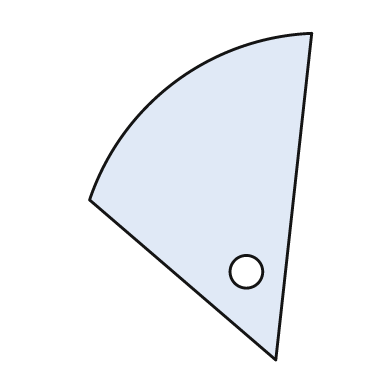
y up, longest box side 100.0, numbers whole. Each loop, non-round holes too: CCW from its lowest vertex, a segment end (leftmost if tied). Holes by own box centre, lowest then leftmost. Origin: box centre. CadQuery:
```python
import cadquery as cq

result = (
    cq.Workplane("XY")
    .moveTo(23.0, -50.0)
    .lineTo(34.0, 50.0)
    .threePointArc((-8.0, 35.0), (-34.0, -1.0))
    .close()
    .moveTo(14.0, -23.0)
    .circle(5.0)
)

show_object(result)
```